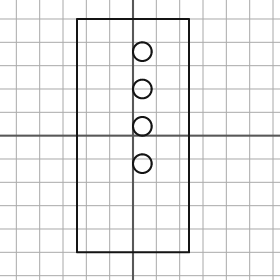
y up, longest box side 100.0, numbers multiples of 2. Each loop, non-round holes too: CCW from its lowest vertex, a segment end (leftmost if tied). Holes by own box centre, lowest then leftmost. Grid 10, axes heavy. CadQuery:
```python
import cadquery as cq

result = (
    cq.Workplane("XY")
    .moveTo(-24.0, -50.0)
    .lineTo(24.0, -50.0)
    .lineTo(24.0, 50.0)
    .lineTo(-24.0, 50.0)
    .close()
    .moveTo(4.0, -12.0)
    .circle(4.0)
    .moveTo(4.0, 4.0)
    .circle(4.0)
    .moveTo(4.0, 20.0)
    .circle(4.0)
    .moveTo(4.0, 36.0)
    .circle(4.0)
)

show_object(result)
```